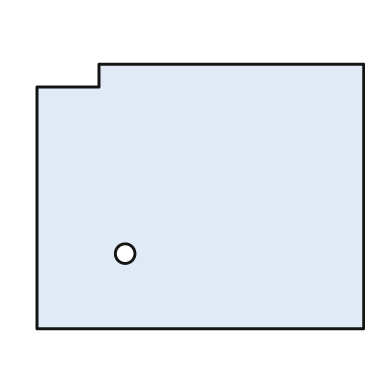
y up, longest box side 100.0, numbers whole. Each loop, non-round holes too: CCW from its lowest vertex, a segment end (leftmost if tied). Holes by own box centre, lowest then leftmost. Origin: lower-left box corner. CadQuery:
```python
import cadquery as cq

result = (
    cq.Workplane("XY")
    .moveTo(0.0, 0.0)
    .lineTo(100.0, 0.0)
    .lineTo(100.0, 81.0)
    .lineTo(19.0, 81.0)
    .lineTo(19.0, 74.0)
    .lineTo(0.0, 74.0)
    .close()
    .moveTo(27.0, 23.0)
    .circle(3.0)
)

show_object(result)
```